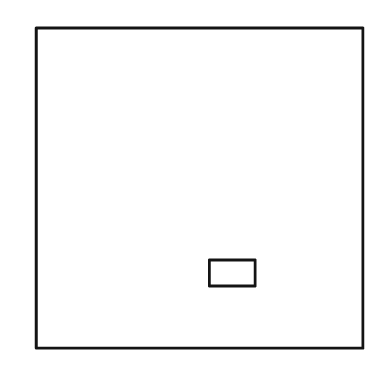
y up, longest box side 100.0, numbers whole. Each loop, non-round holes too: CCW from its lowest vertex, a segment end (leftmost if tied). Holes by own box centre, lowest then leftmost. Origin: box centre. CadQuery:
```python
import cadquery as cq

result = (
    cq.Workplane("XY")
    .moveTo(-50.0, -49.0)
    .lineTo(50.0, -49.0)
    .lineTo(50.0, 49.0)
    .lineTo(-50.0, 49.0)
    .close()
    .moveTo(3.0, -30.0)
    .lineTo(17.0, -30.0)
    .lineTo(17.0, -22.0)
    .lineTo(3.0, -22.0)
    .close()
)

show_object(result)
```